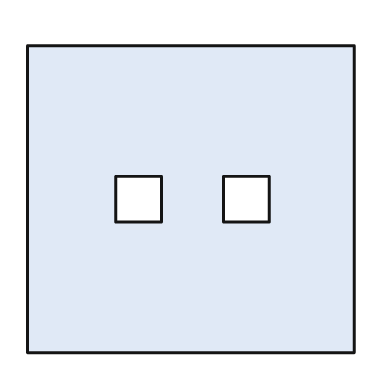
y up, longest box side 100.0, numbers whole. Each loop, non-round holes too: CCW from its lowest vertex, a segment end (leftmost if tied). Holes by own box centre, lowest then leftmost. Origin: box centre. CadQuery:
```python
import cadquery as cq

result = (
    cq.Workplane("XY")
    .moveTo(-50.0, -47.0)
    .lineTo(50.0, -47.0)
    .lineTo(50.0, 47.0)
    .lineTo(-50.0, 47.0)
    .close()
    .moveTo(-23.0, -7.0)
    .lineTo(-9.0, -7.0)
    .lineTo(-9.0, 7.0)
    .lineTo(-23.0, 7.0)
    .close()
    .moveTo(10.0, -7.0)
    .lineTo(24.0, -7.0)
    .lineTo(24.0, 7.0)
    .lineTo(10.0, 7.0)
    .close()
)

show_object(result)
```